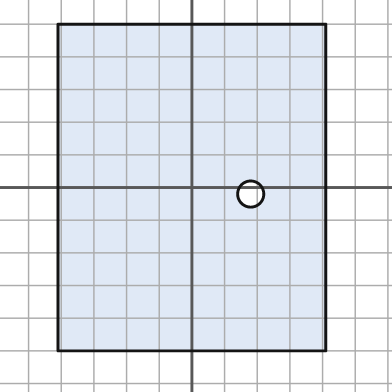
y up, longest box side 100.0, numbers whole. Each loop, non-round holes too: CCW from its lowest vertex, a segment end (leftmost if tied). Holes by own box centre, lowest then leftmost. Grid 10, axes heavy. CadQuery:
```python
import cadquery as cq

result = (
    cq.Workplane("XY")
    .moveTo(-41.0, -50.0)
    .lineTo(41.0, -50.0)
    .lineTo(41.0, 50.0)
    .lineTo(-41.0, 50.0)
    .close()
    .moveTo(18.0, -2.0)
    .circle(4.0)
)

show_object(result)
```